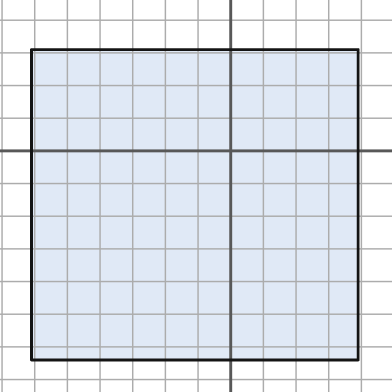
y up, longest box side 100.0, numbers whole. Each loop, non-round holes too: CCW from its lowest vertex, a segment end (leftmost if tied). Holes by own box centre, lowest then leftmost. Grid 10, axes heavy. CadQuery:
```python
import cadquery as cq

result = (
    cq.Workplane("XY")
    .moveTo(-61.0, -64.0)
    .lineTo(39.0, -64.0)
    .lineTo(39.0, 31.0)
    .lineTo(-61.0, 31.0)
    .close()
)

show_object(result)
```